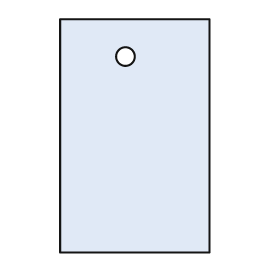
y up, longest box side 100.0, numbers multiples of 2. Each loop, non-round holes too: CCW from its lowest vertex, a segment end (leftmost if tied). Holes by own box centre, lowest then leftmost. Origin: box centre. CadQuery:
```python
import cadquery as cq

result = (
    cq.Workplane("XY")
    .moveTo(-32.0, -50.0)
    .lineTo(32.0, -50.0)
    .lineTo(32.0, 50.0)
    .lineTo(-32.0, 50.0)
    .close()
    .moveTo(-4.0, 34.0)
    .circle(4.0)
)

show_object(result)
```